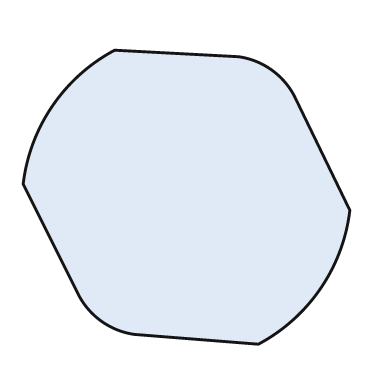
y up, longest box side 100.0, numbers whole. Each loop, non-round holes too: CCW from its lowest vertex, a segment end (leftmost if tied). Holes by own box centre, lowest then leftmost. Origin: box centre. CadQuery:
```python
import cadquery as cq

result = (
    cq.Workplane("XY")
    .moveTo(22.0, -45.0)
    .threePointArc((41.0, -28.0), (50.0, -4.0))
    .lineTo(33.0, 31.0)
    .threePointArc((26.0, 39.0), (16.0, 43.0))
    .lineTo(-22.0, 45.0)
    .threePointArc((-41.0, 28.0), (-50.0, 4.0))
    .lineTo(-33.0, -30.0)
    .threePointArc((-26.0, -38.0), (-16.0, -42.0))
    .close()
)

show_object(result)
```